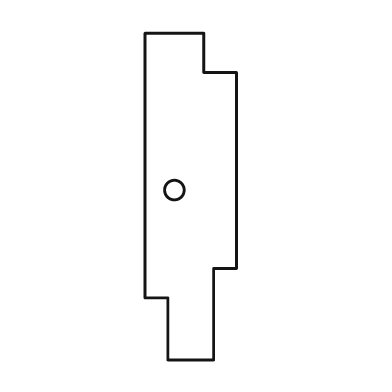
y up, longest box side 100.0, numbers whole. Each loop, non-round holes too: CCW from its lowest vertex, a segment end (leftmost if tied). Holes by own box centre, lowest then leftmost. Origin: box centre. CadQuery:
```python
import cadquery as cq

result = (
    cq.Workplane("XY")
    .moveTo(-7.0, -50.0)
    .lineTo(7.0, -50.0)
    .lineTo(7.0, -22.0)
    .lineTo(14.0, -22.0)
    .lineTo(14.0, 38.0)
    .lineTo(4.0, 38.0)
    .lineTo(4.0, 50.0)
    .lineTo(-14.0, 50.0)
    .lineTo(-14.0, -31.0)
    .lineTo(-7.0, -31.0)
    .close()
    .moveTo(-5.0, 2.0)
    .circle(3.0)
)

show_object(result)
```